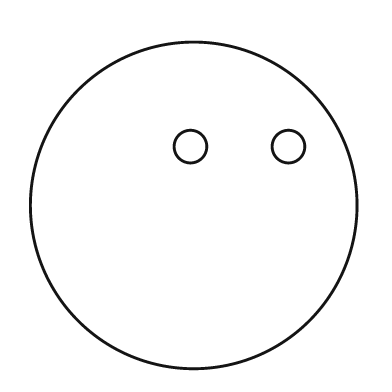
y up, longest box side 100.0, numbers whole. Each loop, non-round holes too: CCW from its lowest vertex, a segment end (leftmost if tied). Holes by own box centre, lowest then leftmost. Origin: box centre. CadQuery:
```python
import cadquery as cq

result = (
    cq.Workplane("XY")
    .moveTo(0.0, 0.0)
    .circle(50.0)
    .moveTo(-1.0, 18.0)
    .circle(5.0)
    .moveTo(29.0, 18.0)
    .circle(5.0)
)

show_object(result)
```